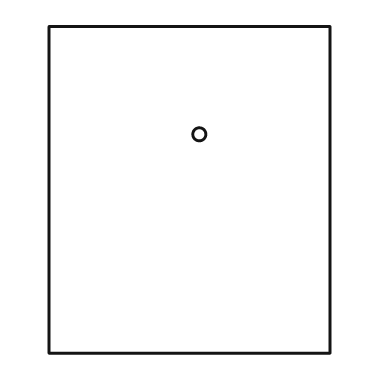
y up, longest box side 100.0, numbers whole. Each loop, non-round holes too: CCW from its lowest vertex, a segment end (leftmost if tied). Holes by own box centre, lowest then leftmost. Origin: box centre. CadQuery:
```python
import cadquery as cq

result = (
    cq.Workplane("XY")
    .moveTo(-43.0, -50.0)
    .lineTo(43.0, -50.0)
    .lineTo(43.0, 50.0)
    .lineTo(-43.0, 50.0)
    .close()
    .moveTo(3.0, 17.0)
    .circle(2.0)
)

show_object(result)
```